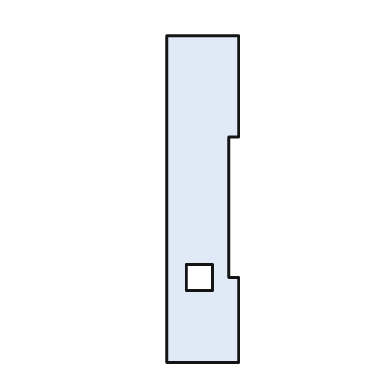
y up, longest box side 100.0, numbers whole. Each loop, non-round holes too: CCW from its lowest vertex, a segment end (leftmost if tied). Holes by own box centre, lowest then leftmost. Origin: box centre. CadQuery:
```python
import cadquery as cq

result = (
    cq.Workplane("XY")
    .moveTo(-11.0, -50.0)
    .lineTo(11.0, -50.0)
    .lineTo(11.0, -24.0)
    .lineTo(8.0, -24.0)
    .lineTo(8.0, 19.0)
    .lineTo(11.0, 19.0)
    .lineTo(11.0, 50.0)
    .lineTo(-11.0, 50.0)
    .close()
    .moveTo(-5.0, -28.0)
    .lineTo(3.0, -28.0)
    .lineTo(3.0, -20.0)
    .lineTo(-5.0, -20.0)
    .close()
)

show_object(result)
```